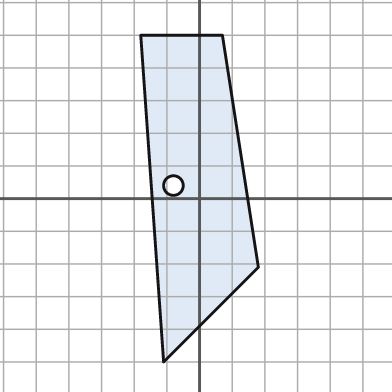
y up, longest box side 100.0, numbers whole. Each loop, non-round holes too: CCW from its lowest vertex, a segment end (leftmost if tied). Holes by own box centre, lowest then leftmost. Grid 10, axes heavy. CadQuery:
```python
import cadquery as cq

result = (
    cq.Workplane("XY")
    .moveTo(-11.0, -50.0)
    .lineTo(18.0, -21.0)
    .lineTo(7.0, 50.0)
    .lineTo(-18.0, 50.0)
    .close()
    .moveTo(-8.0, 4.0)
    .circle(3.0)
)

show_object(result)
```